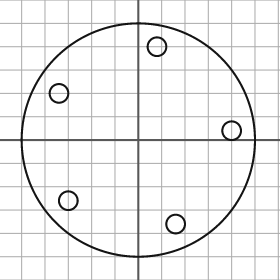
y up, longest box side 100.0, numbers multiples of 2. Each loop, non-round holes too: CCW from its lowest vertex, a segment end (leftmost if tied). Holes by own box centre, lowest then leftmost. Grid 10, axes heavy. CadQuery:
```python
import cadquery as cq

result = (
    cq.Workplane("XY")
    .moveTo(0.0, 0.0)
    .circle(50.0)
    .moveTo(16.0, -36.0)
    .circle(4.0)
    .moveTo(-30.0, -26.0)
    .circle(4.0)
    .moveTo(40.0, 4.0)
    .circle(4.0)
    .moveTo(-34.0, 20.0)
    .circle(4.0)
    .moveTo(8.0, 40.0)
    .circle(4.0)
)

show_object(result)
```